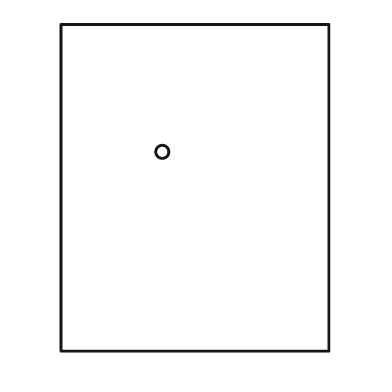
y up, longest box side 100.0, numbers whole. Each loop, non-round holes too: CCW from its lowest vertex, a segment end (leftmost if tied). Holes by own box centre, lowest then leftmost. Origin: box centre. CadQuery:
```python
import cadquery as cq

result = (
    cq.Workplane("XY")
    .moveTo(-41.0, -50.0)
    .lineTo(41.0, -50.0)
    .lineTo(41.0, 50.0)
    .lineTo(-41.0, 50.0)
    .close()
    .moveTo(-10.0, 11.0)
    .circle(2.0)
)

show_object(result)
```